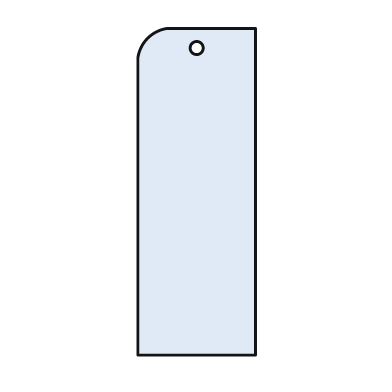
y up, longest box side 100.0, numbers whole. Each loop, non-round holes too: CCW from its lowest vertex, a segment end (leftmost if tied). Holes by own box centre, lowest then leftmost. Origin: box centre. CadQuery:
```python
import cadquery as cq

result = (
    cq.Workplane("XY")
    .moveTo(-18.0, -50.0)
    .lineTo(18.0, -50.0)
    .lineTo(18.0, 50.0)
    .lineTo(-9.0, 50.0)
    .threePointArc((-15.0, 47.0), (-18.0, 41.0))
    .close()
    .moveTo(0.0, 44.0)
    .circle(2.0)
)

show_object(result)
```